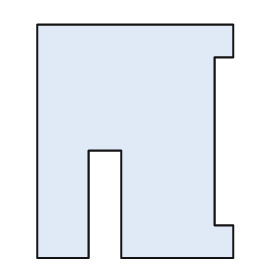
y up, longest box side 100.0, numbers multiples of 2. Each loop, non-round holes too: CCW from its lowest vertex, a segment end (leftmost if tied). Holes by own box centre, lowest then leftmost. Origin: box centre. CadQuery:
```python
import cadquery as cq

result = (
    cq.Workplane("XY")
    .moveTo(-42.0, -50.0)
    .lineTo(-20.0, -50.0)
    .lineTo(-20.0, -4.0)
    .lineTo(-6.0, -4.0)
    .lineTo(-6.0, -50.0)
    .lineTo(42.0, -50.0)
    .lineTo(42.0, -36.0)
    .lineTo(34.0, -36.0)
    .lineTo(34.0, 36.0)
    .lineTo(42.0, 36.0)
    .lineTo(42.0, 50.0)
    .lineTo(-42.0, 50.0)
    .close()
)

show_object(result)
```